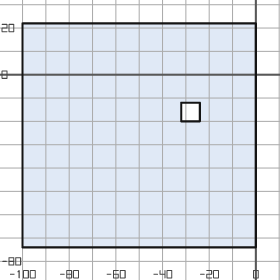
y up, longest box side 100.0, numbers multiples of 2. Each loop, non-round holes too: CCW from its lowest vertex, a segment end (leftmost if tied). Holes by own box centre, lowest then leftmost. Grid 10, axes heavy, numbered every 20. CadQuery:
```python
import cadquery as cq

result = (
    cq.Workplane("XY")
    .moveTo(-100.0, -74.0)
    .lineTo(0.0, -74.0)
    .lineTo(0.0, 22.0)
    .lineTo(-100.0, 22.0)
    .close()
    .moveTo(-32.0, -20.0)
    .lineTo(-24.0, -20.0)
    .lineTo(-24.0, -12.0)
    .lineTo(-32.0, -12.0)
    .close()
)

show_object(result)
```